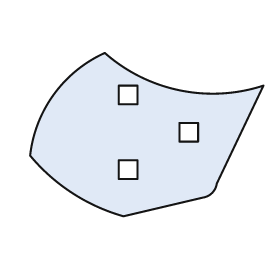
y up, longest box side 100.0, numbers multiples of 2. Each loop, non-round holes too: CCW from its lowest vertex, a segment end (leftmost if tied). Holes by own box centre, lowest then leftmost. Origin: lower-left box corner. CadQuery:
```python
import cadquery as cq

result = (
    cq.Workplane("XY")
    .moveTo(40.0, 0.0)
    .lineTo(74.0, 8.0)
    .threePointArc((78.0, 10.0), (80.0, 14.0))
    .lineTo(100.0, 56.0)
    .threePointArc((64.0, 54.0), (32.0, 70.0))
    .threePointArc((10.0, 52.0), (0.0, 26.0))
    .threePointArc((18.0, 10.0), (40.0, 0.0))
    .close()
    .moveTo(38.0, 16.0)
    .lineTo(46.0, 16.0)
    .lineTo(46.0, 24.0)
    .lineTo(38.0, 24.0)
    .close()
    .moveTo(64.0, 32.0)
    .lineTo(72.0, 32.0)
    .lineTo(72.0, 40.0)
    .lineTo(64.0, 40.0)
    .close()
    .moveTo(38.0, 48.0)
    .lineTo(46.0, 48.0)
    .lineTo(46.0, 56.0)
    .lineTo(38.0, 56.0)
    .close()
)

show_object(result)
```